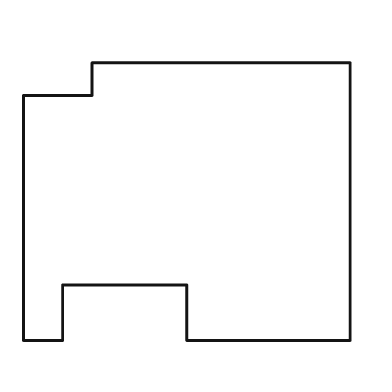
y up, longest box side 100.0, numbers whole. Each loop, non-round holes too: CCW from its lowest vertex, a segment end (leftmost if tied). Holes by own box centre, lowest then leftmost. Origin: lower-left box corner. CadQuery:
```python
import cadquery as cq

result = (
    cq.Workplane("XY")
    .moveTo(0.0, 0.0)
    .lineTo(12.0, 0.0)
    .lineTo(12.0, 17.0)
    .lineTo(50.0, 17.0)
    .lineTo(50.0, 0.0)
    .lineTo(100.0, 0.0)
    .lineTo(100.0, 85.0)
    .lineTo(21.0, 85.0)
    .lineTo(21.0, 75.0)
    .lineTo(0.0, 75.0)
    .close()
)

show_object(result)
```